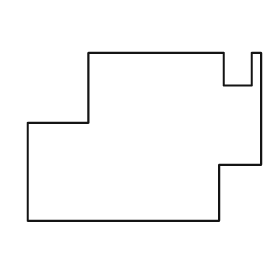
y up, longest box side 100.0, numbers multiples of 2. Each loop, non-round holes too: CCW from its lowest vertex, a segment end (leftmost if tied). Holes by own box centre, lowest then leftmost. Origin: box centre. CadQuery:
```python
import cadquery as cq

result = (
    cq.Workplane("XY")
    .moveTo(-50.0, -36.0)
    .lineTo(32.0, -36.0)
    .lineTo(32.0, -12.0)
    .lineTo(50.0, -12.0)
    .lineTo(50.0, 36.0)
    .lineTo(46.0, 36.0)
    .lineTo(46.0, 22.0)
    .lineTo(34.0, 22.0)
    .lineTo(34.0, 36.0)
    .lineTo(-24.0, 36.0)
    .lineTo(-24.0, 6.0)
    .lineTo(-50.0, 6.0)
    .close()
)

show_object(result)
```